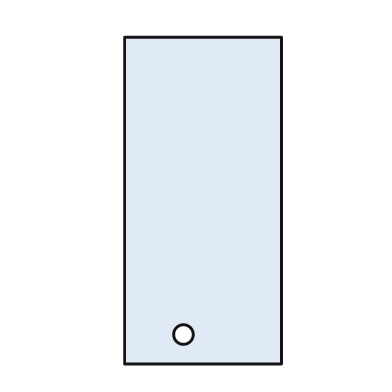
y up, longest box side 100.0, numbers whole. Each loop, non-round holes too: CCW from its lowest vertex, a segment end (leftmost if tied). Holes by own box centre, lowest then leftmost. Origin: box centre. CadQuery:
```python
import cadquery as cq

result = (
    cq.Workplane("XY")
    .moveTo(-24.0, -50.0)
    .lineTo(24.0, -50.0)
    .lineTo(24.0, 50.0)
    .lineTo(-24.0, 50.0)
    .close()
    .moveTo(-6.0, -41.0)
    .circle(3.0)
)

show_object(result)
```